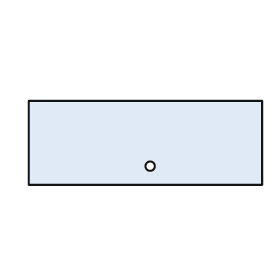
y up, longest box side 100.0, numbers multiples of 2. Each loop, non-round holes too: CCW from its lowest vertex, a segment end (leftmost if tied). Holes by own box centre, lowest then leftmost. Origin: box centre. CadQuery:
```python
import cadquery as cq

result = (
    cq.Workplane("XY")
    .moveTo(-50.0, -18.0)
    .lineTo(50.0, -18.0)
    .lineTo(50.0, 18.0)
    .lineTo(-50.0, 18.0)
    .close()
    .moveTo(2.0, -10.0)
    .circle(2.0)
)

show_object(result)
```